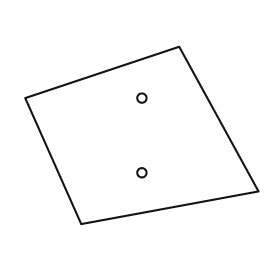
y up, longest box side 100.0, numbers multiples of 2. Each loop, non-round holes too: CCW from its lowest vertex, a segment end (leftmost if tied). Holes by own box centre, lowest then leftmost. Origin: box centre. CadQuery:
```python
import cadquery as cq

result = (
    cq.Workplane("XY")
    .moveTo(-26.0, -38.0)
    .lineTo(50.0, -24.0)
    .lineTo(16.0, 38.0)
    .lineTo(-50.0, 16.0)
    .close()
    .moveTo(0.0, -16.0)
    .circle(2.0)
    .moveTo(0.0, 16.0)
    .circle(2.0)
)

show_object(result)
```